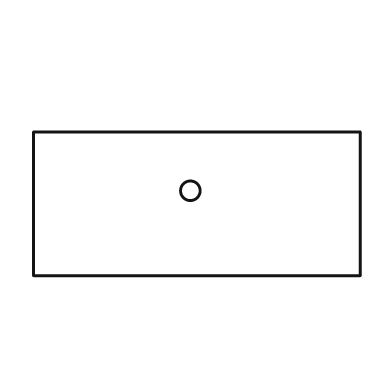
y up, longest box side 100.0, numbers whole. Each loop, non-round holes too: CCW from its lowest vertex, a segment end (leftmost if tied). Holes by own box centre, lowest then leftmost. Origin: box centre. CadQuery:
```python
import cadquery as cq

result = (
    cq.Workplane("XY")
    .moveTo(-50.0, -22.0)
    .lineTo(50.0, -22.0)
    .lineTo(50.0, 22.0)
    .lineTo(-50.0, 22.0)
    .close()
    .moveTo(-2.0, 4.0)
    .circle(3.0)
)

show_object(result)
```